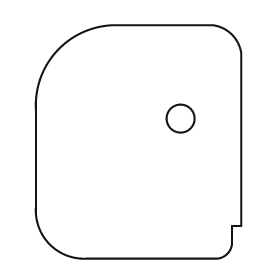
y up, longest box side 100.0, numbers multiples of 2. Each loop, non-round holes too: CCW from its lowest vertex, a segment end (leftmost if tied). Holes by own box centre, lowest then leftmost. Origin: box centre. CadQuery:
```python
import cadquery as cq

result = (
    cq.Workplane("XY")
    .moveTo(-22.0, -50.0)
    .lineTo(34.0, -50.0)
    .threePointArc((38.0, -48.0), (40.0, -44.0))
    .lineTo(40.0, -36.0)
    .lineTo(44.0, -36.0)
    .lineTo(44.0, 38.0)
    .threePointArc((40.0, 46.0), (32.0, 50.0))
    .lineTo(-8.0, 50.0)
    .threePointArc((-34.0, 40.0), (-44.0, 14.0))
    .lineTo(-44.0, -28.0)
    .threePointArc((-38.0, -44.0), (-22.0, -50.0))
    .close()
    .moveTo(18.0, 10.0)
    .circle(6.0)
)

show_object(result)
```